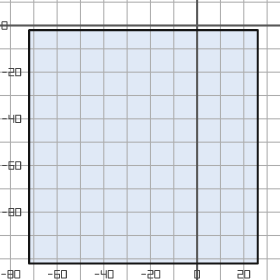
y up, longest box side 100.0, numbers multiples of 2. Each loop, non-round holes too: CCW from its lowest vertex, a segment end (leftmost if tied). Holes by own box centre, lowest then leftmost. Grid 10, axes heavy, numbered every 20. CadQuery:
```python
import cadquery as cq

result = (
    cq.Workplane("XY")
    .moveTo(-72.0, -102.0)
    .lineTo(26.0, -102.0)
    .lineTo(26.0, -2.0)
    .lineTo(-72.0, -2.0)
    .close()
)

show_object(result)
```